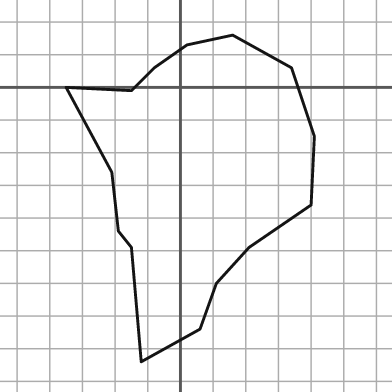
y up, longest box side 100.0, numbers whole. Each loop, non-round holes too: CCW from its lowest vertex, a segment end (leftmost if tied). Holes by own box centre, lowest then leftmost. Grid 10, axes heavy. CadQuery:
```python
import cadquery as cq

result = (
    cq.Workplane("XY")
    .moveTo(-12.0, -84.0)
    .lineTo(6.0, -74.0)
    .lineTo(11.0, -60.0)
    .lineTo(21.0, -49.0)
    .lineTo(40.0, -36.0)
    .lineTo(41.0, -15.0)
    .lineTo(34.0, 6.0)
    .lineTo(16.0, 16.0)
    .lineTo(2.0, 13.0)
    .lineTo(-8.0, 6.0)
    .lineTo(-15.0, -1.0)
    .lineTo(-35.0, 0.0)
    .lineTo(-21.0, -26.0)
    .lineTo(-19.0, -44.0)
    .lineTo(-15.0, -49.0)
    .close()
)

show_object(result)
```